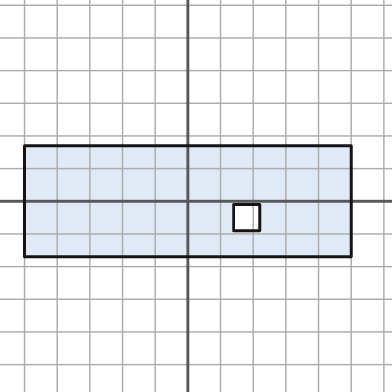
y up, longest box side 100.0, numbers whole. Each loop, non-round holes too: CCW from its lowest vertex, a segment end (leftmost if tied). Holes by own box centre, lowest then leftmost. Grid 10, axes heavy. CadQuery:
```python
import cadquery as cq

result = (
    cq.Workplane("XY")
    .moveTo(-50.0, -17.0)
    .lineTo(50.0, -17.0)
    .lineTo(50.0, 17.0)
    .lineTo(-50.0, 17.0)
    .close()
    .moveTo(14.0, -9.0)
    .lineTo(22.0, -9.0)
    .lineTo(22.0, -1.0)
    .lineTo(14.0, -1.0)
    .close()
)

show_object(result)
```